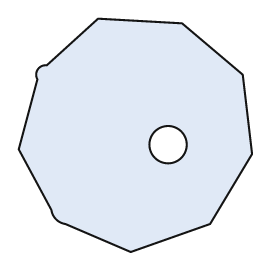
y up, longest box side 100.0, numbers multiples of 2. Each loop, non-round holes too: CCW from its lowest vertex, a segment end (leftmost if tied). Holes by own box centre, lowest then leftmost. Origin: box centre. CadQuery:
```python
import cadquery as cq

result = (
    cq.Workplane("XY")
    .moveTo(-2.0, -50.0)
    .lineTo(32.0, -38.0)
    .lineTo(50.0, -8.0)
    .lineTo(46.0, 26.0)
    .lineTo(20.0, 48.0)
    .lineTo(-16.0, 50.0)
    .lineTo(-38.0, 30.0)
    .threePointArc((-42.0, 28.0), (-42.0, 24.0))
    .lineTo(-50.0, -6.0)
    .lineTo(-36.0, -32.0)
    .threePointArc((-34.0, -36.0), (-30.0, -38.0))
    .close()
    .moveTo(14.0, -4.0)
    .circle(8.0)
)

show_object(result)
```